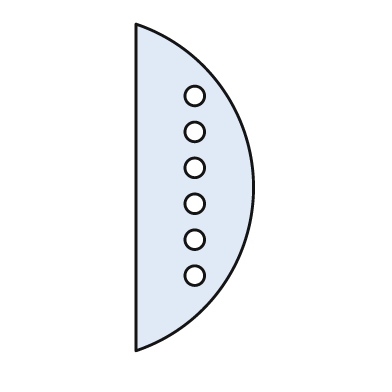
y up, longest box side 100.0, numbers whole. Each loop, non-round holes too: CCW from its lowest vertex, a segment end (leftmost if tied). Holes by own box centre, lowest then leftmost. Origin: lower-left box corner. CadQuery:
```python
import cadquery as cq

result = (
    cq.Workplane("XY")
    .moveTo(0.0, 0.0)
    .threePointArc((36.0, 50.0), (0.0, 100.0))
    .close()
    .moveTo(18.0, 23.0)
    .circle(3.0)
    .moveTo(18.0, 34.0)
    .circle(3.0)
    .moveTo(18.0, 45.0)
    .circle(3.0)
    .moveTo(18.0, 56.0)
    .circle(3.0)
    .moveTo(18.0, 67.0)
    .circle(3.0)
    .moveTo(18.0, 78.0)
    .circle(3.0)
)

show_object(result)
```